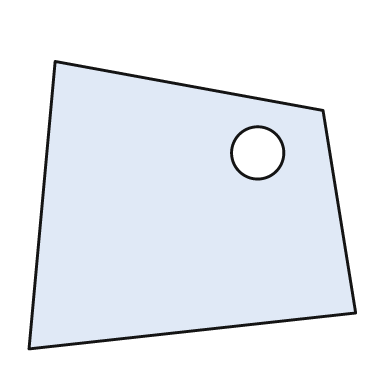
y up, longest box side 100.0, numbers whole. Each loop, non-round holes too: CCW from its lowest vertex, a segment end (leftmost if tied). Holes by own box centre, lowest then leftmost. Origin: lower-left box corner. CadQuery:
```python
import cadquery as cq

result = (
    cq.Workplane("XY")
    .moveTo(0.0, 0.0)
    .lineTo(100.0, 11.0)
    .lineTo(90.0, 73.0)
    .lineTo(8.0, 88.0)
    .close()
    .moveTo(70.0, 60.0)
    .circle(8.0)
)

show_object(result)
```